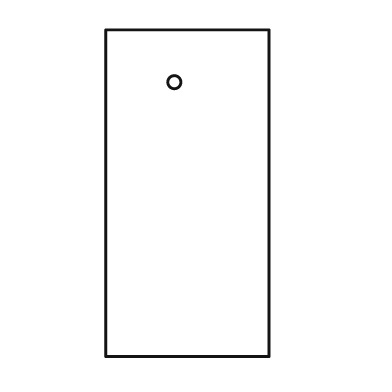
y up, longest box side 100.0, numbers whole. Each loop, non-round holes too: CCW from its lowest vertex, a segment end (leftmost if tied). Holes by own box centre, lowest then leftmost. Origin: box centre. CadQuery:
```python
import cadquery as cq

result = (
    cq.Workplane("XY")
    .moveTo(-25.0, -50.0)
    .lineTo(25.0, -50.0)
    .lineTo(25.0, 50.0)
    .lineTo(-25.0, 50.0)
    .close()
    .moveTo(-4.0, 34.0)
    .circle(2.0)
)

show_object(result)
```